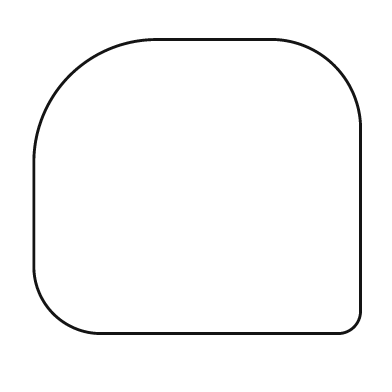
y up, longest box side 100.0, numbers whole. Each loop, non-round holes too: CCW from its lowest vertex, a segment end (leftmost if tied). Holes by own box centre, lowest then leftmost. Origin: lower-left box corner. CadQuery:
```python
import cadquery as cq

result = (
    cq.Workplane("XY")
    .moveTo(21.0, 0.0)
    .lineTo(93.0, 0.0)
    .threePointArc((98.0, 2.0), (100.0, 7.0))
    .lineTo(100.0, 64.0)
    .threePointArc((92.0, 82.0), (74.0, 90.0))
    .lineTo(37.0, 90.0)
    .threePointArc((11.0, 79.0), (0.0, 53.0))
    .lineTo(0.0, 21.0)
    .threePointArc((6.0, 6.0), (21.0, 0.0))
    .close()
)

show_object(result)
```